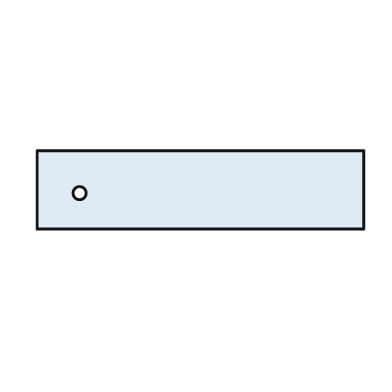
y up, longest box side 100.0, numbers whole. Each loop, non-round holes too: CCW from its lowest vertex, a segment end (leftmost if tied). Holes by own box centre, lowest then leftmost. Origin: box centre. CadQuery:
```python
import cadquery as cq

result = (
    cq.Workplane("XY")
    .moveTo(-50.0, -12.0)
    .lineTo(50.0, -12.0)
    .lineTo(50.0, 12.0)
    .lineTo(-50.0, 12.0)
    .close()
    .moveTo(-37.0, -1.0)
    .circle(2.0)
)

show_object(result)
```